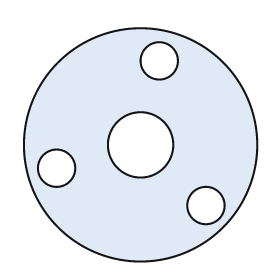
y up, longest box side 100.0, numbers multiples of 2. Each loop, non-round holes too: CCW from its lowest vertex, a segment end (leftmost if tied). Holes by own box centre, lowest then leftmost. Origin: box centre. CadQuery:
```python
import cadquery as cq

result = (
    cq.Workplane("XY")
    .moveTo(0.0, 0.0)
    .circle(50.0)
    .moveTo(28.0, -26.0)
    .circle(8.0)
    .moveTo(-36.0, -10.0)
    .circle(8.0)
    .moveTo(0.0, 0.0)
    .circle(14.0)
    .moveTo(8.0, 36.0)
    .circle(8.0)
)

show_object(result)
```